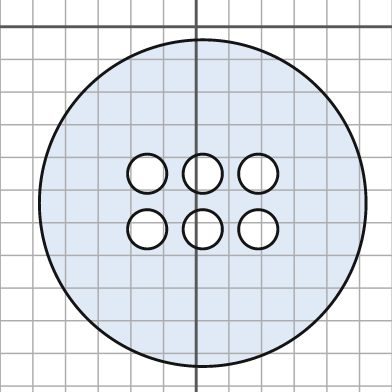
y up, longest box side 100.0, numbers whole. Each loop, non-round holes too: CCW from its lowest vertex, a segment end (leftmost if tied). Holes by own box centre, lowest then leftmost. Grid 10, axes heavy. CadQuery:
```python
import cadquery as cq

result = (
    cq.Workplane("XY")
    .moveTo(2.0, -54.0)
    .circle(50.0)
    .moveTo(-15.0, -62.0)
    .circle(6.0)
    .moveTo(2.0, -62.0)
    .circle(6.0)
    .moveTo(19.0, -62.0)
    .circle(6.0)
    .moveTo(-15.0, -45.0)
    .circle(6.0)
    .moveTo(2.0, -45.0)
    .circle(6.0)
    .moveTo(19.0, -45.0)
    .circle(6.0)
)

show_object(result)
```